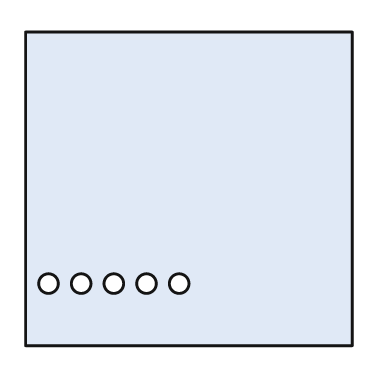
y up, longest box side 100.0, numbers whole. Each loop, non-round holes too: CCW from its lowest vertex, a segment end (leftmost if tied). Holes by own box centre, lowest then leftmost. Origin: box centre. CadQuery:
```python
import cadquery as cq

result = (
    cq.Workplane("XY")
    .moveTo(-50.0, -48.0)
    .lineTo(50.0, -48.0)
    .lineTo(50.0, 48.0)
    .lineTo(-50.0, 48.0)
    .close()
    .moveTo(-43.0, -29.0)
    .circle(3.0)
    .moveTo(-33.0, -29.0)
    .circle(3.0)
    .moveTo(-23.0, -29.0)
    .circle(3.0)
    .moveTo(-13.0, -29.0)
    .circle(3.0)
    .moveTo(-3.0, -29.0)
    .circle(3.0)
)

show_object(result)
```